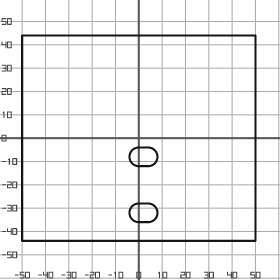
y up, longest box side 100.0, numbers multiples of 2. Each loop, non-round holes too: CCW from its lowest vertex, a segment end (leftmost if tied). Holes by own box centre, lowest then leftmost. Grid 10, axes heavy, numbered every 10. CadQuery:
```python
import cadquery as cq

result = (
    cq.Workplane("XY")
    .moveTo(-50.0, -44.0)
    .lineTo(50.0, -44.0)
    .lineTo(50.0, 44.0)
    .lineTo(-50.0, 44.0)
    .close()
    .moveTo(0.0, -36.0)
    .lineTo(4.0, -36.0)
    .threePointArc((8.0, -32.0), (4.0, -28.0))
    .lineTo(0.0, -28.0)
    .threePointArc((-4.0, -32.0), (0.0, -36.0))
    .close()
    .moveTo(0.0, -12.0)
    .lineTo(4.0, -12.0)
    .threePointArc((8.0, -8.0), (4.0, -4.0))
    .lineTo(0.0, -4.0)
    .threePointArc((-4.0, -8.0), (0.0, -12.0))
    .close()
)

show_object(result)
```